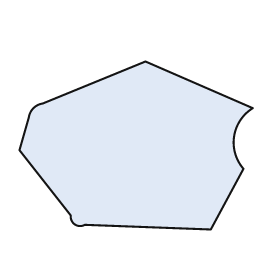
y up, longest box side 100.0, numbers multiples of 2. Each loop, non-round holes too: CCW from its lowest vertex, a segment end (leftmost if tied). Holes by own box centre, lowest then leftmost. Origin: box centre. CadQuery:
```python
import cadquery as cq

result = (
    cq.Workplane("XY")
    .moveTo(32.0, -36.0)
    .lineTo(46.0, -10.0)
    .threePointArc((42.0, 4.0), (50.0, 16.0))
    .lineTo(4.0, 36.0)
    .lineTo(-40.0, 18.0)
    .threePointArc((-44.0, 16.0), (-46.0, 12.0))
    .lineTo(-50.0, -2.0)
    .lineTo(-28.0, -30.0)
    .threePointArc((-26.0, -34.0), (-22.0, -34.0))
    .close()
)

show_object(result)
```